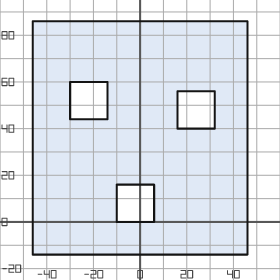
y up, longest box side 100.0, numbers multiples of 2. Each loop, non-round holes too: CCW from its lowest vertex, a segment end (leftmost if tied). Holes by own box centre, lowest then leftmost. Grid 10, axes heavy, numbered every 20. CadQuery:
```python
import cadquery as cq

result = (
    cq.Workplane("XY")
    .moveTo(-46.0, -14.0)
    .lineTo(46.0, -14.0)
    .lineTo(46.0, 86.0)
    .lineTo(-46.0, 86.0)
    .close()
    .moveTo(-10.0, 0.0)
    .lineTo(6.0, 0.0)
    .lineTo(6.0, 16.0)
    .lineTo(-10.0, 16.0)
    .close()
    .moveTo(16.0, 40.0)
    .lineTo(32.0, 40.0)
    .lineTo(32.0, 56.0)
    .lineTo(16.0, 56.0)
    .close()
    .moveTo(-30.0, 44.0)
    .lineTo(-14.0, 44.0)
    .lineTo(-14.0, 60.0)
    .lineTo(-30.0, 60.0)
    .close()
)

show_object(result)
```